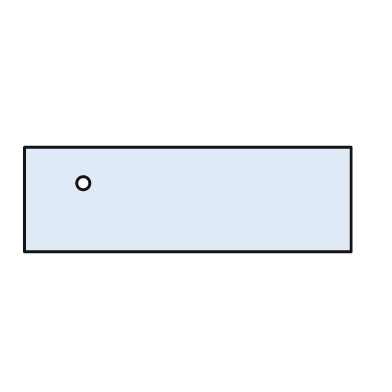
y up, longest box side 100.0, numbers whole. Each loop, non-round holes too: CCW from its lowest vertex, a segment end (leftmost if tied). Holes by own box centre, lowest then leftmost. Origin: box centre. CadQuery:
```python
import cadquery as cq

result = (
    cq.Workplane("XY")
    .moveTo(-50.0, -16.0)
    .lineTo(50.0, -16.0)
    .lineTo(50.0, 16.0)
    .lineTo(-50.0, 16.0)
    .close()
    .moveTo(-32.0, 5.0)
    .circle(2.0)
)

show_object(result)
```